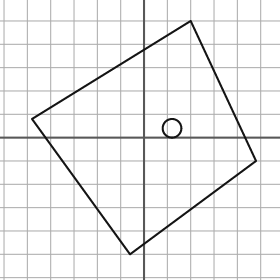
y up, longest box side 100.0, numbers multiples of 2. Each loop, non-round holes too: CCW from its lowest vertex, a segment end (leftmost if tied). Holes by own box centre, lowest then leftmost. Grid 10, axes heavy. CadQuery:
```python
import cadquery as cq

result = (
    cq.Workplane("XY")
    .moveTo(-6.0, -50.0)
    .lineTo(48.0, -10.0)
    .lineTo(20.0, 50.0)
    .lineTo(-48.0, 8.0)
    .close()
    .moveTo(12.0, 4.0)
    .circle(4.0)
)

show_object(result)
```